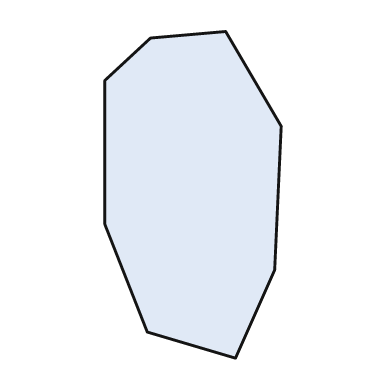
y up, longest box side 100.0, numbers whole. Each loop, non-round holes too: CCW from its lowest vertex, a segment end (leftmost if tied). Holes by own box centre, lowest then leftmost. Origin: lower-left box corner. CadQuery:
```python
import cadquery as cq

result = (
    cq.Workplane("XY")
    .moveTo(40.0, 0.0)
    .lineTo(52.0, 27.0)
    .lineTo(54.0, 71.0)
    .lineTo(37.0, 100.0)
    .lineTo(14.0, 98.0)
    .lineTo(0.0, 85.0)
    .lineTo(0.0, 41.0)
    .lineTo(13.0, 8.0)
    .close()
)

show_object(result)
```